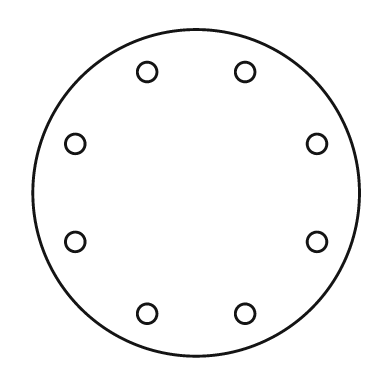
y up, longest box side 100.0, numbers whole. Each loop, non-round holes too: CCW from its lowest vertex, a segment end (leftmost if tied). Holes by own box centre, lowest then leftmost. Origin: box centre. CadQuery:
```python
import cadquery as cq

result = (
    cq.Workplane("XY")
    .moveTo(0.0, 0.0)
    .circle(50.0)
    .moveTo(-15.0, -37.0)
    .circle(3.0)
    .moveTo(15.0, -37.0)
    .circle(3.0)
    .moveTo(-37.0, -15.0)
    .circle(3.0)
    .moveTo(37.0, -15.0)
    .circle(3.0)
    .moveTo(-37.0, 15.0)
    .circle(3.0)
    .moveTo(37.0, 15.0)
    .circle(3.0)
    .moveTo(-15.0, 37.0)
    .circle(3.0)
    .moveTo(15.0, 37.0)
    .circle(3.0)
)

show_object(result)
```